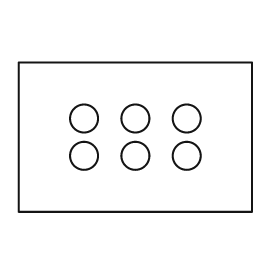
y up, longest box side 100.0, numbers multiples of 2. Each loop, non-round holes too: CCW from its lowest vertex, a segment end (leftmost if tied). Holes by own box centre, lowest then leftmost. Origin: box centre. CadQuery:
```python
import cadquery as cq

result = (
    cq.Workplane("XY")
    .moveTo(-50.0, -32.0)
    .lineTo(50.0, -32.0)
    .lineTo(50.0, 32.0)
    .lineTo(-50.0, 32.0)
    .close()
    .moveTo(-22.0, -8.0)
    .circle(6.0)
    .moveTo(0.0, -8.0)
    .circle(6.0)
    .moveTo(22.0, -8.0)
    .circle(6.0)
    .moveTo(-22.0, 8.0)
    .circle(6.0)
    .moveTo(0.0, 8.0)
    .circle(6.0)
    .moveTo(22.0, 8.0)
    .circle(6.0)
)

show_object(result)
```